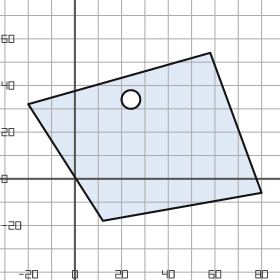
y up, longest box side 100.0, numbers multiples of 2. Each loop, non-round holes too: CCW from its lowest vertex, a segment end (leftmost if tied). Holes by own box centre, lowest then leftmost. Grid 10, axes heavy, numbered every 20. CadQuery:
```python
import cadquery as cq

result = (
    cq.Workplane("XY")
    .moveTo(12.0, -18.0)
    .lineTo(80.0, -6.0)
    .lineTo(58.0, 54.0)
    .lineTo(-20.0, 32.0)
    .close()
    .moveTo(24.0, 34.0)
    .circle(4.0)
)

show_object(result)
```